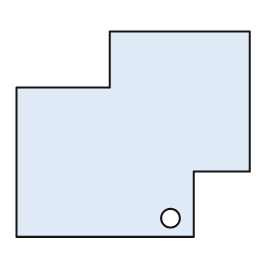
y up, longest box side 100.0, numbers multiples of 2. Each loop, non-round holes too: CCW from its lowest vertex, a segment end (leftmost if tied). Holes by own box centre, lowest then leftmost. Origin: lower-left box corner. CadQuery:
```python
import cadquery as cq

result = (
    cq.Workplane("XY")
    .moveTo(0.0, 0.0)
    .lineTo(76.0, 0.0)
    .lineTo(76.0, 28.0)
    .lineTo(100.0, 28.0)
    .lineTo(100.0, 88.0)
    .lineTo(40.0, 88.0)
    .lineTo(40.0, 64.0)
    .lineTo(0.0, 64.0)
    .close()
    .moveTo(66.0, 8.0)
    .circle(4.0)
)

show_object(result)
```